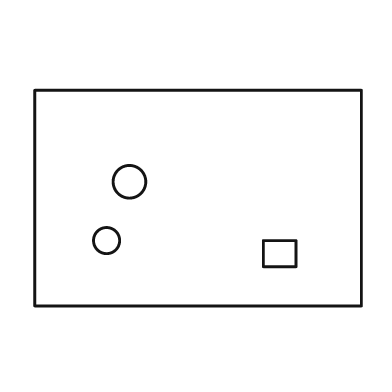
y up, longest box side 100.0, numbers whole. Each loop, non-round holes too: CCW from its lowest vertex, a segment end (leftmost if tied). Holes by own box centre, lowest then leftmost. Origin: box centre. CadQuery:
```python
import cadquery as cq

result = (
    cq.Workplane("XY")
    .moveTo(-50.0, -33.0)
    .lineTo(50.0, -33.0)
    .lineTo(50.0, 33.0)
    .lineTo(-50.0, 33.0)
    .close()
    .moveTo(20.0, -21.0)
    .lineTo(30.0, -21.0)
    .lineTo(30.0, -13.0)
    .lineTo(20.0, -13.0)
    .close()
    .moveTo(-28.0, -13.0)
    .circle(4.0)
    .moveTo(-21.0, 5.0)
    .circle(5.0)
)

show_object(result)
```